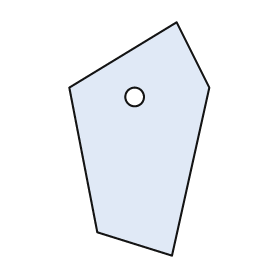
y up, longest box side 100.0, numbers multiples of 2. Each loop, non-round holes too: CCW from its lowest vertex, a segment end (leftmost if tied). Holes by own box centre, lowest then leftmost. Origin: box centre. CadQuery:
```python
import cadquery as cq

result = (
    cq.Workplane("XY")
    .moveTo(14.0, -50.0)
    .lineTo(30.0, 22.0)
    .lineTo(16.0, 50.0)
    .lineTo(-30.0, 22.0)
    .lineTo(-18.0, -40.0)
    .close()
    .moveTo(-2.0, 18.0)
    .circle(4.0)
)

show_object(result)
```